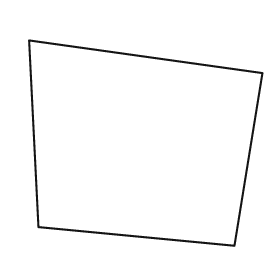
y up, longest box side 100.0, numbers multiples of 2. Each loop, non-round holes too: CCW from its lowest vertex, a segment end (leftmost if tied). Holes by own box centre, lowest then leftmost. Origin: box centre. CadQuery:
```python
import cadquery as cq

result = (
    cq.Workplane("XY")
    .moveTo(38.0, -44.0)
    .lineTo(50.0, 30.0)
    .lineTo(-50.0, 44.0)
    .lineTo(-46.0, -36.0)
    .close()
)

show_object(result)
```